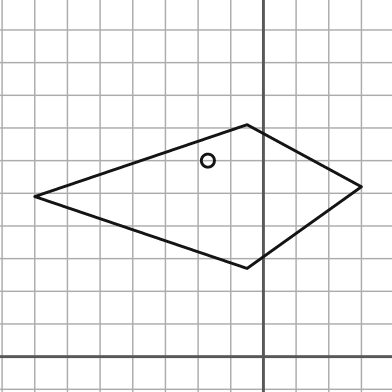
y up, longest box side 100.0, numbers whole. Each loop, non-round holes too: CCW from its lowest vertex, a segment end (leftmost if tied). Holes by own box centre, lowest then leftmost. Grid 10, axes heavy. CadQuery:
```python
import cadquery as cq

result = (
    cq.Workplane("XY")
    .moveTo(-5.0, 27.0)
    .lineTo(30.0, 52.0)
    .lineTo(-5.0, 71.0)
    .lineTo(-70.0, 49.0)
    .close()
    .moveTo(-17.0, 60.0)
    .circle(2.0)
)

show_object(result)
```